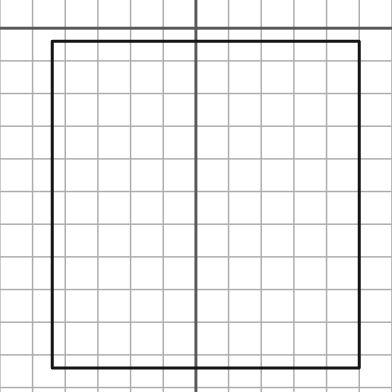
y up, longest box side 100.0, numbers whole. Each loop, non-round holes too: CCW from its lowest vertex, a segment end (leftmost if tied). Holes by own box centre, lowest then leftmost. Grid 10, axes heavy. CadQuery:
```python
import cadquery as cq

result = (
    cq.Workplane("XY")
    .moveTo(-44.0, -104.0)
    .lineTo(50.0, -104.0)
    .lineTo(50.0, -4.0)
    .lineTo(-44.0, -4.0)
    .close()
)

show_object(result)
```